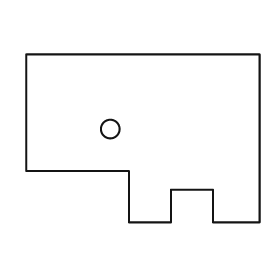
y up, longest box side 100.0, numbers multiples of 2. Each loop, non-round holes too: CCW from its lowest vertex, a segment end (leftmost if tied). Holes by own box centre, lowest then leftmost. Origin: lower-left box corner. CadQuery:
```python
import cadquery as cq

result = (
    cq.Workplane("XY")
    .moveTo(44.0, 0.0)
    .lineTo(62.0, 0.0)
    .lineTo(62.0, 14.0)
    .lineTo(80.0, 14.0)
    .lineTo(80.0, 0.0)
    .lineTo(100.0, 0.0)
    .lineTo(100.0, 72.0)
    .lineTo(0.0, 72.0)
    .lineTo(0.0, 22.0)
    .lineTo(44.0, 22.0)
    .close()
    .moveTo(36.0, 40.0)
    .circle(4.0)
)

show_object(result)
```